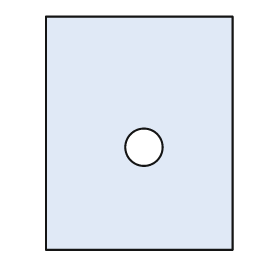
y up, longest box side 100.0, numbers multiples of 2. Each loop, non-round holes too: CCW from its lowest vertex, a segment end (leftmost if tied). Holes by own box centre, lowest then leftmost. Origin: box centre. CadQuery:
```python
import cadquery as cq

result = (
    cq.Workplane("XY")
    .moveTo(-40.0, -50.0)
    .lineTo(40.0, -50.0)
    .lineTo(40.0, 50.0)
    .lineTo(-40.0, 50.0)
    .close()
    .moveTo(2.0, -6.0)
    .circle(8.0)
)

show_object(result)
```